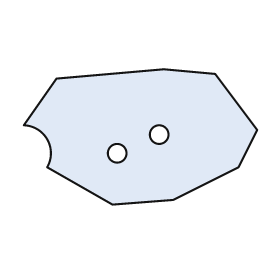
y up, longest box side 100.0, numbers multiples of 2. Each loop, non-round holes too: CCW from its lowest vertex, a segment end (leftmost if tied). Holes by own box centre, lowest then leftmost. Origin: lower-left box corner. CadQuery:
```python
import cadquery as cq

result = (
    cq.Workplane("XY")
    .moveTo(38.0, 0.0)
    .lineTo(64.0, 2.0)
    .lineTo(92.0, 16.0)
    .lineTo(100.0, 32.0)
    .lineTo(82.0, 56.0)
    .lineTo(60.0, 58.0)
    .lineTo(14.0, 54.0)
    .lineTo(0.0, 34.0)
    .threePointArc((10.0, 28.0), (10.0, 16.0))
    .close()
    .moveTo(40.0, 22.0)
    .circle(4.0)
    .moveTo(58.0, 30.0)
    .circle(4.0)
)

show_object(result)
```